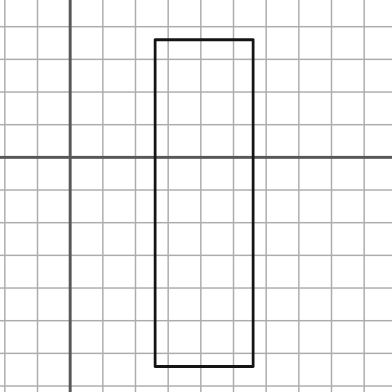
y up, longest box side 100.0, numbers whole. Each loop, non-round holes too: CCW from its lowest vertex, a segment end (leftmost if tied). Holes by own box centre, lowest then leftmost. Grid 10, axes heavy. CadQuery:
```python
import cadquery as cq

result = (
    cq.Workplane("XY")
    .moveTo(26.0, -64.0)
    .lineTo(56.0, -64.0)
    .lineTo(56.0, 36.0)
    .lineTo(26.0, 36.0)
    .close()
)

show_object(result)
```